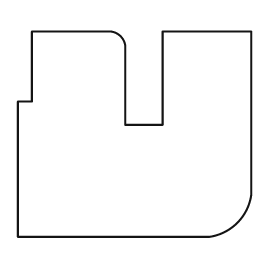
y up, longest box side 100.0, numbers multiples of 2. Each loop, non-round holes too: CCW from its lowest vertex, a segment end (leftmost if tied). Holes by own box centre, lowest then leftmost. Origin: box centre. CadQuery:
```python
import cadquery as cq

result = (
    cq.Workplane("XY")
    .moveTo(-50.0, -44.0)
    .lineTo(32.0, -44.0)
    .threePointArc((44.0, -38.0), (50.0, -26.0))
    .lineTo(50.0, 44.0)
    .lineTo(12.0, 44.0)
    .lineTo(12.0, 4.0)
    .lineTo(-4.0, 4.0)
    .lineTo(-4.0, 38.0)
    .threePointArc((-6.0, 42.0), (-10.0, 44.0))
    .lineTo(-44.0, 44.0)
    .lineTo(-44.0, 14.0)
    .lineTo(-50.0, 14.0)
    .close()
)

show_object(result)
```